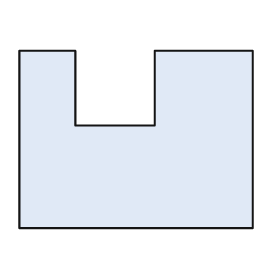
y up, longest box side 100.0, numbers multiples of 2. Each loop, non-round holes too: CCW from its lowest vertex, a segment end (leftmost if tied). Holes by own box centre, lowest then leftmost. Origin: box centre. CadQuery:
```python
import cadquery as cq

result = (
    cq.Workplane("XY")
    .moveTo(-50.0, -38.0)
    .lineTo(50.0, -38.0)
    .lineTo(50.0, 38.0)
    .lineTo(8.0, 38.0)
    .lineTo(8.0, 6.0)
    .lineTo(-26.0, 6.0)
    .lineTo(-26.0, 38.0)
    .lineTo(-50.0, 38.0)
    .close()
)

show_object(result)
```